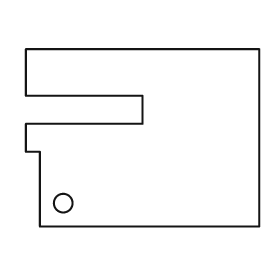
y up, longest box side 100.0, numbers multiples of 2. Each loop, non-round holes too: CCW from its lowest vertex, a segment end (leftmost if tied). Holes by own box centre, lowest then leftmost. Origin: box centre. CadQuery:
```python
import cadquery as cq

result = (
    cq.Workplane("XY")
    .moveTo(-44.0, -38.0)
    .lineTo(50.0, -38.0)
    .lineTo(50.0, 38.0)
    .lineTo(-50.0, 38.0)
    .lineTo(-50.0, 18.0)
    .lineTo(0.0, 18.0)
    .lineTo(0.0, 6.0)
    .lineTo(-50.0, 6.0)
    .lineTo(-50.0, -6.0)
    .lineTo(-44.0, -6.0)
    .close()
    .moveTo(-34.0, -28.0)
    .circle(4.0)
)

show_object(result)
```